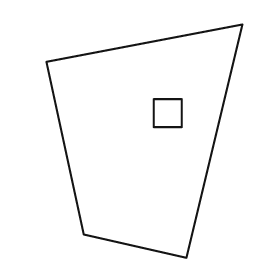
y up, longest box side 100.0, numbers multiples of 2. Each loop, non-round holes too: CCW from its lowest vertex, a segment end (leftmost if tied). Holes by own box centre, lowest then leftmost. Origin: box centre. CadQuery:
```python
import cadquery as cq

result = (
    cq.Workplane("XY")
    .moveTo(18.0, -50.0)
    .lineTo(42.0, 50.0)
    .lineTo(-42.0, 34.0)
    .lineTo(-26.0, -40.0)
    .close()
    .moveTo(4.0, 6.0)
    .lineTo(16.0, 6.0)
    .lineTo(16.0, 18.0)
    .lineTo(4.0, 18.0)
    .close()
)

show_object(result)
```